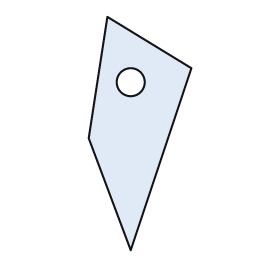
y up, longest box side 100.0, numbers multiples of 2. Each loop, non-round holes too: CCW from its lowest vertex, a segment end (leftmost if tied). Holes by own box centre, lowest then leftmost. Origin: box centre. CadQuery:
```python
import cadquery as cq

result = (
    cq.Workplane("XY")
    .moveTo(-4.0, -50.0)
    .lineTo(22.0, 28.0)
    .lineTo(-14.0, 50.0)
    .lineTo(-22.0, -2.0)
    .close()
    .moveTo(-4.0, 22.0)
    .circle(6.0)
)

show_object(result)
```